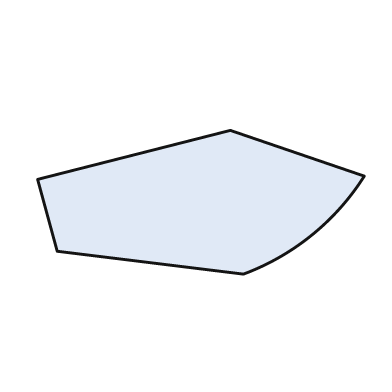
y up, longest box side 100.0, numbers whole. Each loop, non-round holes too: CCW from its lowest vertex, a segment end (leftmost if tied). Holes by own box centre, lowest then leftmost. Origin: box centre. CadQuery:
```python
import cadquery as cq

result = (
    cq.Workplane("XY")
    .moveTo(13.0, -22.0)
    .threePointArc((34.0, -10.0), (50.0, 8.0))
    .lineTo(9.0, 22.0)
    .lineTo(-50.0, 7.0)
    .lineTo(-44.0, -15.0)
    .close()
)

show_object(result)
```